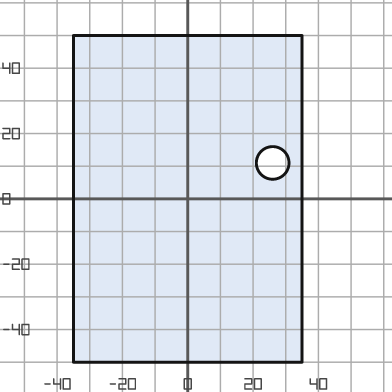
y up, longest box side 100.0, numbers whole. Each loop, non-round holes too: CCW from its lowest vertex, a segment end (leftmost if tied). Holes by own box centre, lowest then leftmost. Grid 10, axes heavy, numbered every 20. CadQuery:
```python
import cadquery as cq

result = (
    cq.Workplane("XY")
    .moveTo(-35.0, -50.0)
    .lineTo(35.0, -50.0)
    .lineTo(35.0, 50.0)
    .lineTo(-35.0, 50.0)
    .close()
    .moveTo(26.0, 11.0)
    .circle(5.0)
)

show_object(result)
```